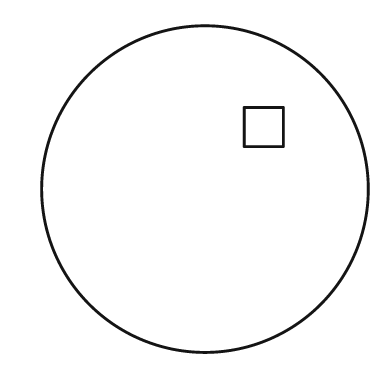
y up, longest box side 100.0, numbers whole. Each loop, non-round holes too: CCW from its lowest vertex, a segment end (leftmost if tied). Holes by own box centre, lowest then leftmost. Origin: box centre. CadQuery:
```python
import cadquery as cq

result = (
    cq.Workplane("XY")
    .moveTo(0.0, 0.0)
    .circle(50.0)
    .moveTo(12.0, 13.0)
    .lineTo(24.0, 13.0)
    .lineTo(24.0, 25.0)
    .lineTo(12.0, 25.0)
    .close()
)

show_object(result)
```